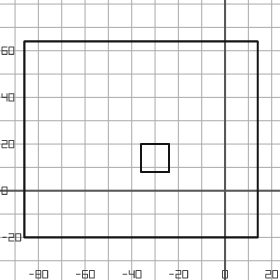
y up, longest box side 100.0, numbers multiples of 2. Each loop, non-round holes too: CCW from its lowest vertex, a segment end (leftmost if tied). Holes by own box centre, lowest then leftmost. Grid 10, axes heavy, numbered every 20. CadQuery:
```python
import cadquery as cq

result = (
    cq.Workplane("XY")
    .moveTo(-86.0, -20.0)
    .lineTo(14.0, -20.0)
    .lineTo(14.0, 64.0)
    .lineTo(-86.0, 64.0)
    .close()
    .moveTo(-36.0, 8.0)
    .lineTo(-24.0, 8.0)
    .lineTo(-24.0, 20.0)
    .lineTo(-36.0, 20.0)
    .close()
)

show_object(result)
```